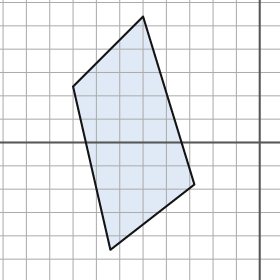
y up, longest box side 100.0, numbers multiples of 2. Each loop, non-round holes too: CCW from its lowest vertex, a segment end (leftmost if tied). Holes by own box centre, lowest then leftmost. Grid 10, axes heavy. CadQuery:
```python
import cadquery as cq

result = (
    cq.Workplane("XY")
    .moveTo(-64.0, -46.0)
    .lineTo(-28.0, -18.0)
    .lineTo(-50.0, 54.0)
    .lineTo(-80.0, 24.0)
    .close()
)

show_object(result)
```